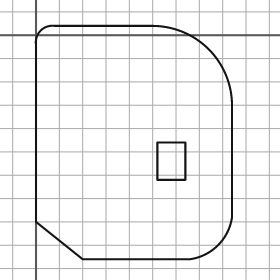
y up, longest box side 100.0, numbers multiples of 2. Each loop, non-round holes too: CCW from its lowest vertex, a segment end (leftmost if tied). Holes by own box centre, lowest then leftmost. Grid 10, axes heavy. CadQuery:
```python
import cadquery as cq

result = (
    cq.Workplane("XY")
    .moveTo(20.0, -96.0)
    .lineTo(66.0, -96.0)
    .threePointArc((78.0, -90.0), (84.0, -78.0))
    .lineTo(84.0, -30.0)
    .threePointArc((74.0, -6.0), (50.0, 4.0))
    .lineTo(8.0, 4.0)
    .threePointArc((2.0, 2.0), (0.0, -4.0))
    .lineTo(0.0, -80.0)
    .close()
    .moveTo(52.0, -62.0)
    .lineTo(64.0, -62.0)
    .lineTo(64.0, -46.0)
    .lineTo(52.0, -46.0)
    .close()
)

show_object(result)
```